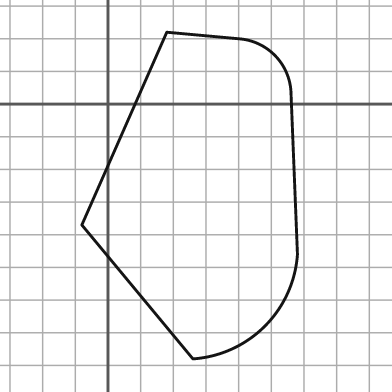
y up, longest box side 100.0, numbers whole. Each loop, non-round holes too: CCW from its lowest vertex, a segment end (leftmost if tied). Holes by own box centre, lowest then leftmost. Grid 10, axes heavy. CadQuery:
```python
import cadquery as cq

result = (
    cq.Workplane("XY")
    .moveTo(26.0, -78.0)
    .threePointArc((48.0, -68.0), (58.0, -46.0))
    .lineTo(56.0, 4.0)
    .threePointArc((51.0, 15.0), (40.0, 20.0))
    .lineTo(18.0, 22.0)
    .lineTo(-8.0, -37.0)
    .close()
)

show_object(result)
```